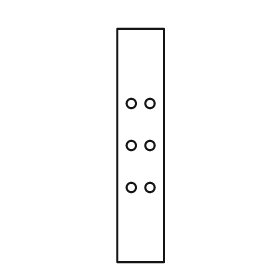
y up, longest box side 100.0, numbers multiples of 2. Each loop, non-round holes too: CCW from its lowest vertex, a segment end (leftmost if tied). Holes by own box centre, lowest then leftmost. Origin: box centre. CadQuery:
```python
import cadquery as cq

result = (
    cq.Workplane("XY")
    .moveTo(-10.0, -50.0)
    .lineTo(10.0, -50.0)
    .lineTo(10.0, 50.0)
    .lineTo(-10.0, 50.0)
    .close()
    .moveTo(-4.0, -18.0)
    .circle(2.0)
    .moveTo(4.0, -18.0)
    .circle(2.0)
    .moveTo(-4.0, 0.0)
    .circle(2.0)
    .moveTo(4.0, 0.0)
    .circle(2.0)
    .moveTo(-4.0, 18.0)
    .circle(2.0)
    .moveTo(4.0, 18.0)
    .circle(2.0)
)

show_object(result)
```